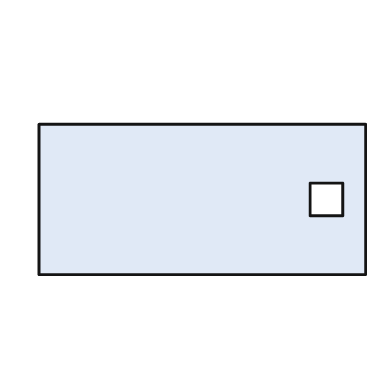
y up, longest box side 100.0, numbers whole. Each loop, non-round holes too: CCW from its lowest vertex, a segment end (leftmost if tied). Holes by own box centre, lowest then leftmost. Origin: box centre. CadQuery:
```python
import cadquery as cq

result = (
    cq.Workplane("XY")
    .moveTo(-50.0, -23.0)
    .lineTo(50.0, -23.0)
    .lineTo(50.0, 23.0)
    .lineTo(-50.0, 23.0)
    .close()
    .moveTo(33.0, -5.0)
    .lineTo(43.0, -5.0)
    .lineTo(43.0, 5.0)
    .lineTo(33.0, 5.0)
    .close()
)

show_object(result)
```